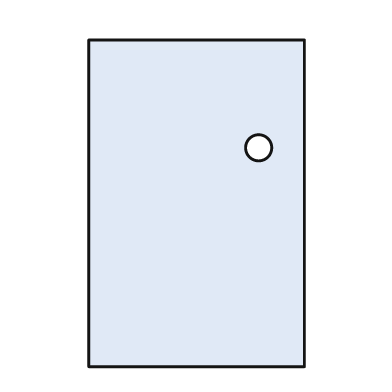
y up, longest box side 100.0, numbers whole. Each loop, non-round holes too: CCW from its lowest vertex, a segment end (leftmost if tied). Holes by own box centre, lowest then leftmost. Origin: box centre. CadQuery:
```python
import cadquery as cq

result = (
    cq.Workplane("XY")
    .moveTo(-33.0, -50.0)
    .lineTo(33.0, -50.0)
    .lineTo(33.0, 50.0)
    .lineTo(-33.0, 50.0)
    .close()
    .moveTo(19.0, 17.0)
    .circle(4.0)
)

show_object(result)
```